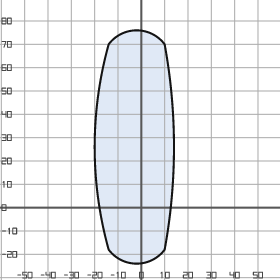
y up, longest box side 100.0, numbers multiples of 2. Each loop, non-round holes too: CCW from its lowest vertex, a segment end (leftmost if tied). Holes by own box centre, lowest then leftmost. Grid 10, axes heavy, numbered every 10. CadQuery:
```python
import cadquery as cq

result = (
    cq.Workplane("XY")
    .moveTo(-14.0, -18.0)
    .threePointArc((-2.0, -24.0), (10.0, -18.0))
    .threePointArc((14.0, 26.0), (10.0, 70.0))
    .threePointArc((-2.0, 76.0), (-14.0, 70.0))
    .threePointArc((-20.0, 26.0), (-14.0, -18.0))
    .close()
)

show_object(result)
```